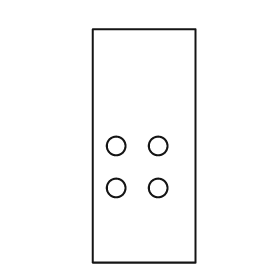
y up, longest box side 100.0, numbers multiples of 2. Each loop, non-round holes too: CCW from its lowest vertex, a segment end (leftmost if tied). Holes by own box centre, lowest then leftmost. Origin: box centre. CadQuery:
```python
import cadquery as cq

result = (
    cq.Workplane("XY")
    .moveTo(-22.0, -50.0)
    .lineTo(22.0, -50.0)
    .lineTo(22.0, 50.0)
    .lineTo(-22.0, 50.0)
    .close()
    .moveTo(-12.0, -18.0)
    .circle(4.0)
    .moveTo(6.0, -18.0)
    .circle(4.0)
    .moveTo(-12.0, 0.0)
    .circle(4.0)
    .moveTo(6.0, 0.0)
    .circle(4.0)
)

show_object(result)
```